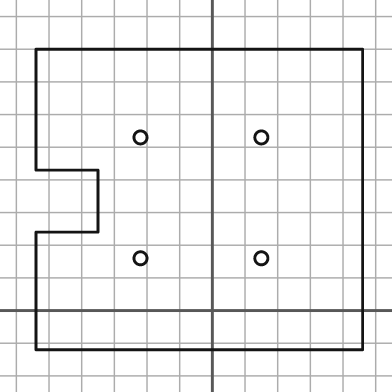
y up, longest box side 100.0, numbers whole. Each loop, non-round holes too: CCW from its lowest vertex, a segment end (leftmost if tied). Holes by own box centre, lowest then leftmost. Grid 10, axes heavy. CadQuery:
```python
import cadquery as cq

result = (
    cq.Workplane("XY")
    .moveTo(-54.0, -12.0)
    .lineTo(46.0, -12.0)
    .lineTo(46.0, 80.0)
    .lineTo(-54.0, 80.0)
    .lineTo(-54.0, 43.0)
    .lineTo(-35.0, 43.0)
    .lineTo(-35.0, 24.0)
    .lineTo(-54.0, 24.0)
    .close()
    .moveTo(-22.0, 16.0)
    .circle(2.0)
    .moveTo(15.0, 16.0)
    .circle(2.0)
    .moveTo(-22.0, 53.0)
    .circle(2.0)
    .moveTo(15.0, 53.0)
    .circle(2.0)
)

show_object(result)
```